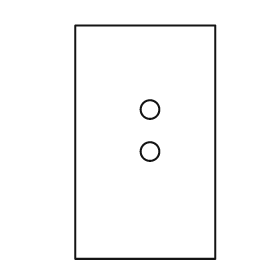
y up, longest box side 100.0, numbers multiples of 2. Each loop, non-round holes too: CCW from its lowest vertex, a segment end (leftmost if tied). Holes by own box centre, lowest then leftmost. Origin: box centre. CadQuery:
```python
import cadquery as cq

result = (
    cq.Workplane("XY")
    .moveTo(-30.0, -50.0)
    .lineTo(30.0, -50.0)
    .lineTo(30.0, 50.0)
    .lineTo(-30.0, 50.0)
    .close()
    .moveTo(2.0, -4.0)
    .circle(4.0)
    .moveTo(2.0, 14.0)
    .circle(4.0)
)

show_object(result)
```